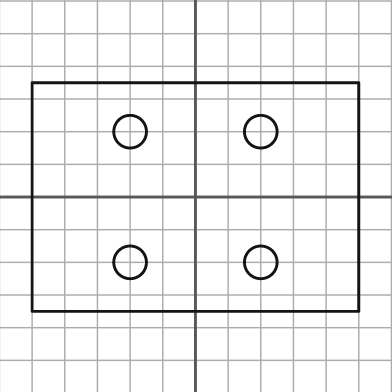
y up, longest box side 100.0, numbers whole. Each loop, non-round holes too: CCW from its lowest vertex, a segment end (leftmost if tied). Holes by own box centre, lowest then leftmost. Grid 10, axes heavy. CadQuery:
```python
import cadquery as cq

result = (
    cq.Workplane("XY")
    .moveTo(-50.0, -35.0)
    .lineTo(50.0, -35.0)
    .lineTo(50.0, 35.0)
    .lineTo(-50.0, 35.0)
    .close()
    .moveTo(-20.0, -20.0)
    .circle(5.0)
    .moveTo(20.0, -20.0)
    .circle(5.0)
    .moveTo(-20.0, 20.0)
    .circle(5.0)
    .moveTo(20.0, 20.0)
    .circle(5.0)
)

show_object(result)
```